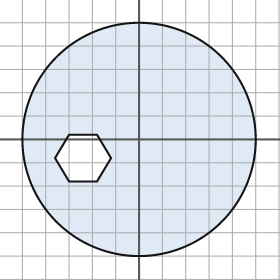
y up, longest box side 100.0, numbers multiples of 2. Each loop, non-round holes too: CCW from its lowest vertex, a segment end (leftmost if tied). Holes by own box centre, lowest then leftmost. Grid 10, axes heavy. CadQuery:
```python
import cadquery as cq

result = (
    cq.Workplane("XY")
    .moveTo(0.0, 0.0)
    .circle(50.0)
    .moveTo(-30.0, -18.0)
    .lineTo(-18.0, -18.0)
    .lineTo(-12.0, -8.0)
    .lineTo(-18.0, 2.0)
    .lineTo(-30.0, 2.0)
    .lineTo(-36.0, -8.0)
    .close()
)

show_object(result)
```